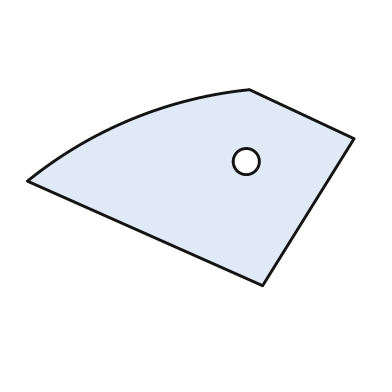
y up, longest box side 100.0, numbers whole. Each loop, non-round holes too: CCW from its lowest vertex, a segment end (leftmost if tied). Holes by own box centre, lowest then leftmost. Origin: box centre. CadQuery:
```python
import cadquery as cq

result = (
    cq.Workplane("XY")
    .moveTo(22.0, -30.0)
    .lineTo(50.0, 15.0)
    .lineTo(18.0, 30.0)
    .threePointArc((-18.0, 21.0), (-50.0, 2.0))
    .close()
    .moveTo(17.0, 8.0)
    .circle(4.0)
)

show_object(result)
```